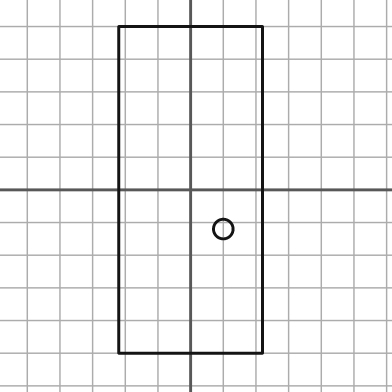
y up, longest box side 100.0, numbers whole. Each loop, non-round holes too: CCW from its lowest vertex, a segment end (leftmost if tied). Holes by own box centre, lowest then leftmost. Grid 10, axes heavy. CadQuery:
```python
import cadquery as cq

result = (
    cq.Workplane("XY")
    .moveTo(-22.0, -50.0)
    .lineTo(22.0, -50.0)
    .lineTo(22.0, 50.0)
    .lineTo(-22.0, 50.0)
    .close()
    .moveTo(10.0, -12.0)
    .circle(3.0)
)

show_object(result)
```